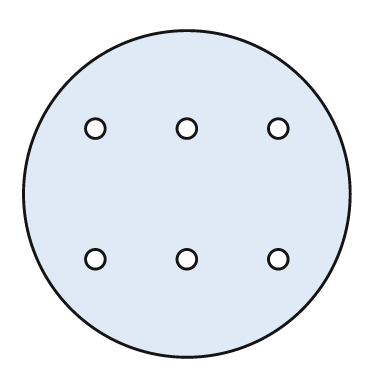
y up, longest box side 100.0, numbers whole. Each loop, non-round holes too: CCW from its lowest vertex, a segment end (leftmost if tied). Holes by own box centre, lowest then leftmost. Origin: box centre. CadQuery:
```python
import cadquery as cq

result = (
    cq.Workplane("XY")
    .moveTo(0.0, 0.0)
    .circle(50.0)
    .moveTo(-28.0, -20.0)
    .circle(3.0)
    .moveTo(0.0, -20.0)
    .circle(3.0)
    .moveTo(28.0, -20.0)
    .circle(3.0)
    .moveTo(-28.0, 20.0)
    .circle(3.0)
    .moveTo(0.0, 20.0)
    .circle(3.0)
    .moveTo(28.0, 20.0)
    .circle(3.0)
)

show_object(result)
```